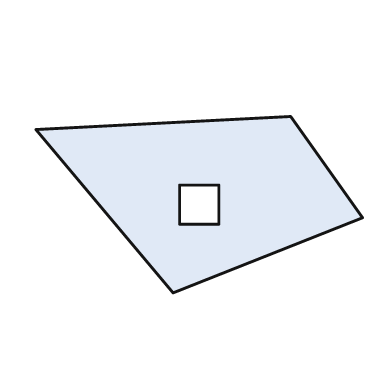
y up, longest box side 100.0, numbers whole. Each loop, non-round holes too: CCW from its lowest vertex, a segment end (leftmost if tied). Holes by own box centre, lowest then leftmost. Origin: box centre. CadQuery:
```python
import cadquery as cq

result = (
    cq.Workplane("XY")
    .moveTo(-8.0, -27.0)
    .lineTo(50.0, -4.0)
    .lineTo(28.0, 27.0)
    .lineTo(-50.0, 23.0)
    .close()
    .moveTo(-6.0, -6.0)
    .lineTo(6.0, -6.0)
    .lineTo(6.0, 6.0)
    .lineTo(-6.0, 6.0)
    .close()
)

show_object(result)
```